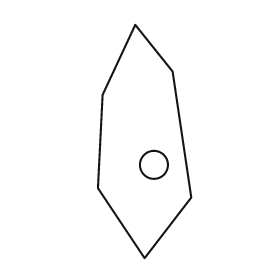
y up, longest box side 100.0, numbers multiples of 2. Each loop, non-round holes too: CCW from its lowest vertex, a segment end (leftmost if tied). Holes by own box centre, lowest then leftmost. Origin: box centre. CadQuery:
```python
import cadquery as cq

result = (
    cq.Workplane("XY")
    .moveTo(0.0, -50.0)
    .lineTo(20.0, -24.0)
    .lineTo(12.0, 30.0)
    .lineTo(-4.0, 50.0)
    .lineTo(-18.0, 20.0)
    .lineTo(-20.0, -20.0)
    .close()
    .moveTo(4.0, -10.0)
    .circle(6.0)
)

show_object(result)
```